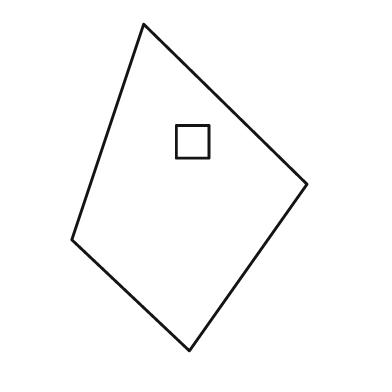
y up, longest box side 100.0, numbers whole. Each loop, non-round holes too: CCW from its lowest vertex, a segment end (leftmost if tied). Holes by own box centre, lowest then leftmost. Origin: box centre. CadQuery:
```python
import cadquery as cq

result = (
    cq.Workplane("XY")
    .moveTo(0.0, -50.0)
    .lineTo(36.0, 1.0)
    .lineTo(-14.0, 50.0)
    .lineTo(-36.0, -16.0)
    .close()
    .moveTo(-4.0, 9.0)
    .lineTo(6.0, 9.0)
    .lineTo(6.0, 19.0)
    .lineTo(-4.0, 19.0)
    .close()
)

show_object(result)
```